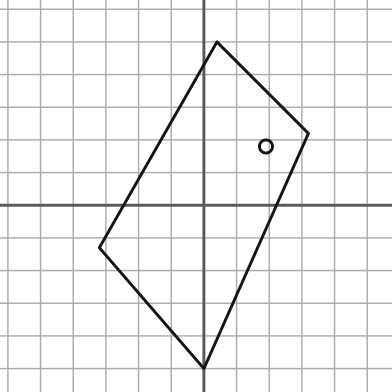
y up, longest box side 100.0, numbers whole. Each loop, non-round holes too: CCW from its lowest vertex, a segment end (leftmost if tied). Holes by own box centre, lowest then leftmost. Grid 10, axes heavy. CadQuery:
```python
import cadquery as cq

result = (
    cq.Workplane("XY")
    .moveTo(0.0, -50.0)
    .lineTo(32.0, 22.0)
    .lineTo(4.0, 50.0)
    .lineTo(-32.0, -13.0)
    .close()
    .moveTo(19.0, 18.0)
    .circle(2.0)
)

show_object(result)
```